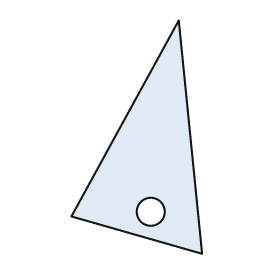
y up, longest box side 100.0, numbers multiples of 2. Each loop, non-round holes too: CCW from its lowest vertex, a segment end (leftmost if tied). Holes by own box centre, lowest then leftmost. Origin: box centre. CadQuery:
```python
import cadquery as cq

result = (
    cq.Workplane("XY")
    .moveTo(28.0, -50.0)
    .lineTo(18.0, 50.0)
    .lineTo(-28.0, -34.0)
    .close()
    .moveTo(6.0, -32.0)
    .circle(6.0)
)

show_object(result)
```